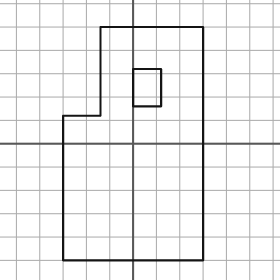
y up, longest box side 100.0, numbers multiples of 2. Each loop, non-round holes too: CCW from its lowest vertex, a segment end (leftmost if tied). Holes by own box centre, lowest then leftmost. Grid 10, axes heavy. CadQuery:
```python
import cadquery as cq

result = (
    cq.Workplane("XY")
    .moveTo(-30.0, -50.0)
    .lineTo(30.0, -50.0)
    .lineTo(30.0, 50.0)
    .lineTo(-14.0, 50.0)
    .lineTo(-14.0, 12.0)
    .lineTo(-30.0, 12.0)
    .close()
    .moveTo(0.0, 16.0)
    .lineTo(12.0, 16.0)
    .lineTo(12.0, 32.0)
    .lineTo(0.0, 32.0)
    .close()
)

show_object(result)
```